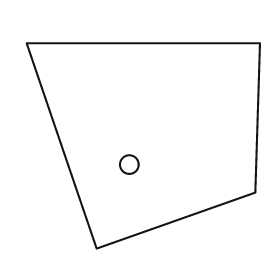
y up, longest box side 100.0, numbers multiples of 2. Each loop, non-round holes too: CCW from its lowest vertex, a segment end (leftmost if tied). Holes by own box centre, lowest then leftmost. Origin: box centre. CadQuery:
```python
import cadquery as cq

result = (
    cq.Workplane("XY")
    .moveTo(-20.0, -44.0)
    .lineTo(48.0, -20.0)
    .lineTo(50.0, 44.0)
    .lineTo(-50.0, 44.0)
    .close()
    .moveTo(-6.0, -8.0)
    .circle(4.0)
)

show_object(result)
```